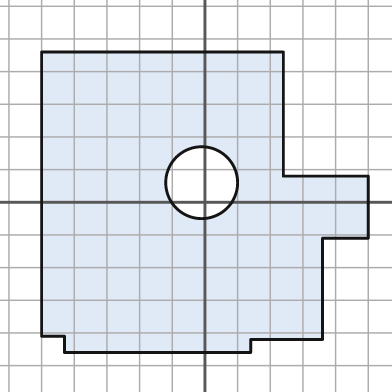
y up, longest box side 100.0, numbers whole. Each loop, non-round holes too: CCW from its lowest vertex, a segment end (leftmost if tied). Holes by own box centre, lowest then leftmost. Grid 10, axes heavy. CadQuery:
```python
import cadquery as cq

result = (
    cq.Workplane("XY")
    .moveTo(-43.0, -46.0)
    .lineTo(14.0, -46.0)
    .lineTo(14.0, -42.0)
    .lineTo(36.0, -42.0)
    .lineTo(36.0, -11.0)
    .lineTo(50.0, -11.0)
    .lineTo(50.0, 8.0)
    .lineTo(24.0, 8.0)
    .lineTo(24.0, 46.0)
    .lineTo(-50.0, 46.0)
    .lineTo(-50.0, -41.0)
    .lineTo(-43.0, -41.0)
    .close()
    .moveTo(-1.0, 6.0)
    .circle(11.0)
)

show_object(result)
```